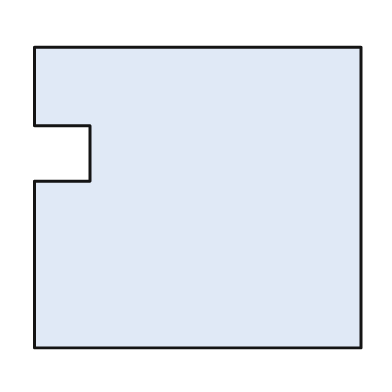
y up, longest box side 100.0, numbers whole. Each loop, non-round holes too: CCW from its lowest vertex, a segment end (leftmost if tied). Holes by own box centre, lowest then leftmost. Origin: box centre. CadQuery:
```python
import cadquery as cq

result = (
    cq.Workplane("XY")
    .moveTo(-50.0, -46.0)
    .lineTo(50.0, -46.0)
    .lineTo(50.0, 46.0)
    .lineTo(-50.0, 46.0)
    .lineTo(-50.0, 22.0)
    .lineTo(-33.0, 22.0)
    .lineTo(-33.0, 5.0)
    .lineTo(-50.0, 5.0)
    .close()
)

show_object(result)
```